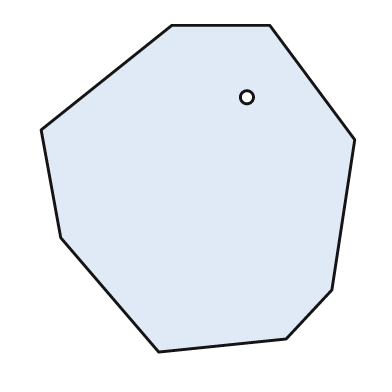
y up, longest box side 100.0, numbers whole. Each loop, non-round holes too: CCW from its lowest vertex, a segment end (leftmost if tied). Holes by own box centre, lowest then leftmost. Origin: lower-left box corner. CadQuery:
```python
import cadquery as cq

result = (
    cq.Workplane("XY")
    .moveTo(36.0, 0.0)
    .lineTo(75.0, 4.0)
    .lineTo(89.0, 19.0)
    .lineTo(96.0, 65.0)
    .lineTo(70.0, 100.0)
    .lineTo(40.0, 100.0)
    .lineTo(0.0, 68.0)
    .lineTo(6.0, 35.0)
    .close()
    .moveTo(63.0, 78.0)
    .circle(2.0)
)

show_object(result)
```